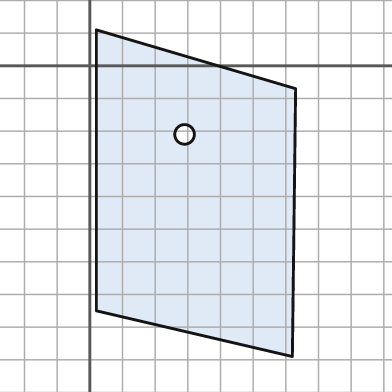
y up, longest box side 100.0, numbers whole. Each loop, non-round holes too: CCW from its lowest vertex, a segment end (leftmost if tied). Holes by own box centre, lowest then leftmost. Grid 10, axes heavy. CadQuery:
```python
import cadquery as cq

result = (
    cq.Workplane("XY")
    .moveTo(62.0, -89.0)
    .lineTo(63.0, -7.0)
    .lineTo(2.0, 11.0)
    .lineTo(2.0, -75.0)
    .close()
    .moveTo(29.0, -21.0)
    .circle(3.0)
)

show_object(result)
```